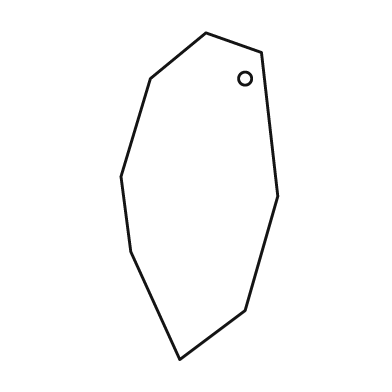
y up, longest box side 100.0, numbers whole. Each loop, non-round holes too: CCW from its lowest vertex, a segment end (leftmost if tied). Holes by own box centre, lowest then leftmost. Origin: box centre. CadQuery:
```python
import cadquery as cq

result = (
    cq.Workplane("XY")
    .moveTo(-6.0, -50.0)
    .lineTo(14.0, -35.0)
    .lineTo(24.0, 0.0)
    .lineTo(19.0, 44.0)
    .lineTo(2.0, 50.0)
    .lineTo(-15.0, 36.0)
    .lineTo(-24.0, 6.0)
    .lineTo(-21.0, -17.0)
    .close()
    .moveTo(14.0, 36.0)
    .circle(2.0)
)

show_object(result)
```